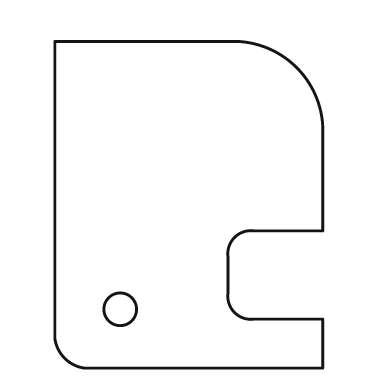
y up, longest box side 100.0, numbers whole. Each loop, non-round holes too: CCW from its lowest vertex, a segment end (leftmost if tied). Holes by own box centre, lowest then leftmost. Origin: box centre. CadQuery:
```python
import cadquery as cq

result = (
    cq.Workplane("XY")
    .moveTo(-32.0, -50.0)
    .lineTo(41.0, -50.0)
    .lineTo(41.0, -35.0)
    .lineTo(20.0, -35.0)
    .threePointArc((14.0, -33.0), (12.0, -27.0))
    .lineTo(12.0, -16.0)
    .threePointArc((14.0, -10.0), (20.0, -8.0))
    .lineTo(41.0, -8.0)
    .lineTo(41.0, 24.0)
    .threePointArc((33.0, 42.0), (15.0, 50.0))
    .lineTo(-41.0, 50.0)
    .lineTo(-41.0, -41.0)
    .threePointArc((-38.0, -47.0), (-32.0, -50.0))
    .close()
    .moveTo(-21.0, -32.0)
    .circle(5.0)
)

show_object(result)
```